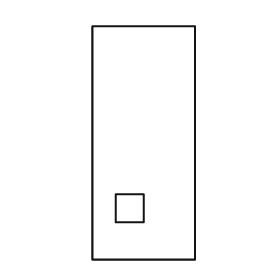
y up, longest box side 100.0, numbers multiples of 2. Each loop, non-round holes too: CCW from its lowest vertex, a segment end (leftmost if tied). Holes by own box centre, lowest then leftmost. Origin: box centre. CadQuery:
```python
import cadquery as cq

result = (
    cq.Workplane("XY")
    .moveTo(-22.0, -50.0)
    .lineTo(22.0, -50.0)
    .lineTo(22.0, 50.0)
    .lineTo(-22.0, 50.0)
    .close()
    .moveTo(-12.0, -34.0)
    .lineTo(0.0, -34.0)
    .lineTo(0.0, -22.0)
    .lineTo(-12.0, -22.0)
    .close()
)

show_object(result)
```